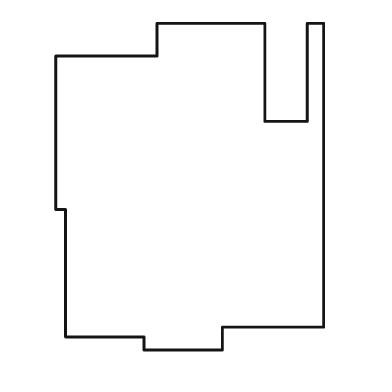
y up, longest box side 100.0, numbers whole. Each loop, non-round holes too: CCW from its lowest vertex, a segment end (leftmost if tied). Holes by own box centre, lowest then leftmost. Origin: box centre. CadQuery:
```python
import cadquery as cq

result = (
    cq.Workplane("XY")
    .moveTo(-14.0, -50.0)
    .lineTo(10.0, -50.0)
    .lineTo(10.0, -43.0)
    .lineTo(41.0, -43.0)
    .lineTo(41.0, 50.0)
    .lineTo(36.0, 50.0)
    .lineTo(36.0, 20.0)
    .lineTo(23.0, 20.0)
    .lineTo(23.0, 50.0)
    .lineTo(-10.0, 50.0)
    .lineTo(-10.0, 40.0)
    .lineTo(-41.0, 40.0)
    .lineTo(-41.0, -7.0)
    .lineTo(-38.0, -7.0)
    .lineTo(-38.0, -46.0)
    .lineTo(-14.0, -46.0)
    .close()
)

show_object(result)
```